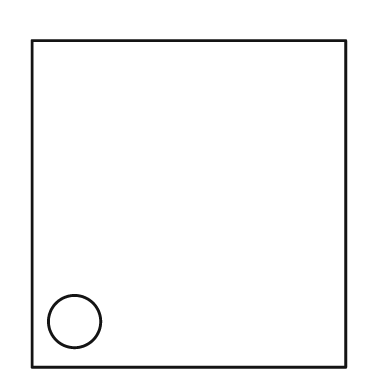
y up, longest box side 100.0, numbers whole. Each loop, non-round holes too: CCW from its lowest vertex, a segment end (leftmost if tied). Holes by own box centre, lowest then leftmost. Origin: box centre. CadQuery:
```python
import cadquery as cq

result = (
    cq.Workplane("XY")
    .moveTo(-48.0, -50.0)
    .lineTo(48.0, -50.0)
    .lineTo(48.0, 50.0)
    .lineTo(-48.0, 50.0)
    .close()
    .moveTo(-35.0, -36.0)
    .circle(8.0)
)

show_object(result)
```